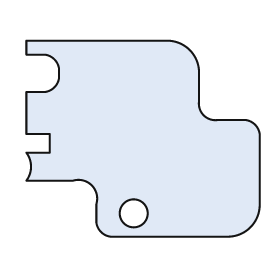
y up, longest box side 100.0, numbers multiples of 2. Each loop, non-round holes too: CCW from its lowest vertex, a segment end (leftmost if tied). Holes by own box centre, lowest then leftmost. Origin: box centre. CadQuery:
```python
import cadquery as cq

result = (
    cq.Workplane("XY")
    .moveTo(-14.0, -42.0)
    .lineTo(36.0, -42.0)
    .threePointArc((46.0, -38.0), (50.0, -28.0))
    .lineTo(50.0, 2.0)
    .threePointArc((48.0, 6.0), (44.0, 8.0))
    .lineTo(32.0, 8.0)
    .threePointArc((26.0, 10.0), (24.0, 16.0))
    .lineTo(24.0, 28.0)
    .threePointArc((20.0, 38.0), (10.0, 42.0))
    .lineTo(-50.0, 42.0)
    .lineTo(-50.0, 36.0)
    .lineTo(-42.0, 36.0)
    .threePointArc((-38.0, 34.0), (-36.0, 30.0))
    .lineTo(-36.0, 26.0)
    .threePointArc((-38.0, 22.0), (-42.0, 20.0))
    .lineTo(-50.0, 20.0)
    .lineTo(-50.0, 2.0)
    .lineTo(-40.0, 2.0)
    .lineTo(-40.0, -6.0)
    .lineTo(-50.0, -6.0)
    .threePointArc((-48.0, -12.0), (-50.0, -18.0))
    .lineTo(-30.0, -18.0)
    .threePointArc((-22.0, -20.0), (-20.0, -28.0))
    .lineTo(-20.0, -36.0)
    .threePointArc((-18.0, -40.0), (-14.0, -42.0))
    .close()
    .moveTo(-4.0, -32.0)
    .circle(6.0)
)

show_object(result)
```